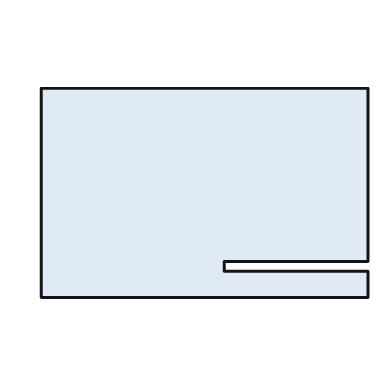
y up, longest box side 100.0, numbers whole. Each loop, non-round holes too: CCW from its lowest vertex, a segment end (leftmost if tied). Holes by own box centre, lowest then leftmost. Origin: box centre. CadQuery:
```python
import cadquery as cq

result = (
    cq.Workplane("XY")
    .moveTo(-50.0, -32.0)
    .lineTo(50.0, -32.0)
    .lineTo(50.0, -24.0)
    .lineTo(6.0, -24.0)
    .lineTo(6.0, -21.0)
    .lineTo(50.0, -21.0)
    .lineTo(50.0, 32.0)
    .lineTo(-50.0, 32.0)
    .close()
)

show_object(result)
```